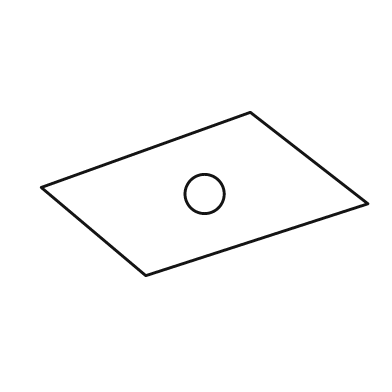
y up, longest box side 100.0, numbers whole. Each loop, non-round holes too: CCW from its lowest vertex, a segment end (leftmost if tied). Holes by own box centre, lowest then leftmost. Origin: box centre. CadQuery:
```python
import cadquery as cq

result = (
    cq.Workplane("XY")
    .moveTo(-18.0, -25.0)
    .lineTo(50.0, -3.0)
    .lineTo(14.0, 25.0)
    .lineTo(-50.0, 2.0)
    .close()
    .moveTo(0.0, 0.0)
    .circle(6.0)
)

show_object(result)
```